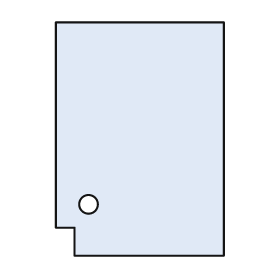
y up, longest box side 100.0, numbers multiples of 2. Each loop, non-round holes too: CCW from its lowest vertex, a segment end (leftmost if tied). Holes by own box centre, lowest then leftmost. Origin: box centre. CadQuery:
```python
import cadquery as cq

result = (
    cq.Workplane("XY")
    .moveTo(-28.0, -50.0)
    .lineTo(36.0, -50.0)
    .lineTo(36.0, 50.0)
    .lineTo(-36.0, 50.0)
    .lineTo(-36.0, -38.0)
    .lineTo(-28.0, -38.0)
    .close()
    .moveTo(-22.0, -28.0)
    .circle(4.0)
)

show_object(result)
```